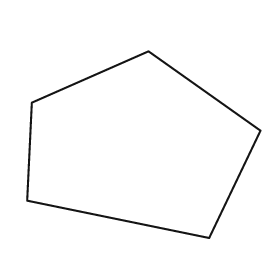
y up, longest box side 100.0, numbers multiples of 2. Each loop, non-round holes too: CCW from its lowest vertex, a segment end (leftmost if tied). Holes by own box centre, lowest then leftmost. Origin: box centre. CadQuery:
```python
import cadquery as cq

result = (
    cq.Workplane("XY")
    .moveTo(28.0, -40.0)
    .lineTo(50.0, 6.0)
    .lineTo(2.0, 40.0)
    .lineTo(-48.0, 18.0)
    .lineTo(-50.0, -24.0)
    .close()
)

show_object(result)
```